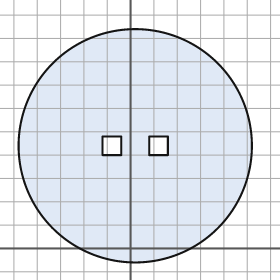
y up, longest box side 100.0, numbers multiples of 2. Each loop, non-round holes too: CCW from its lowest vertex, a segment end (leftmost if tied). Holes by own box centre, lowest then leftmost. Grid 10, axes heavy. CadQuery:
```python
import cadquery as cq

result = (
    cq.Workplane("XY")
    .moveTo(2.0, 44.0)
    .circle(50.0)
    .moveTo(-12.0, 40.0)
    .lineTo(-4.0, 40.0)
    .lineTo(-4.0, 48.0)
    .lineTo(-12.0, 48.0)
    .close()
    .moveTo(8.0, 40.0)
    .lineTo(16.0, 40.0)
    .lineTo(16.0, 48.0)
    .lineTo(8.0, 48.0)
    .close()
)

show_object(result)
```